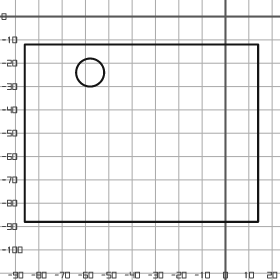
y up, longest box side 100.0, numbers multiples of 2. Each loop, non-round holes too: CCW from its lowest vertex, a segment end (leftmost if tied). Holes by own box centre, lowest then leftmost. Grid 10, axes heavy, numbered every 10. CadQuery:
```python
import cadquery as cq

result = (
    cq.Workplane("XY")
    .moveTo(-86.0, -88.0)
    .lineTo(14.0, -88.0)
    .lineTo(14.0, -12.0)
    .lineTo(-86.0, -12.0)
    .close()
    .moveTo(-58.0, -24.0)
    .circle(6.0)
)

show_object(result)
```